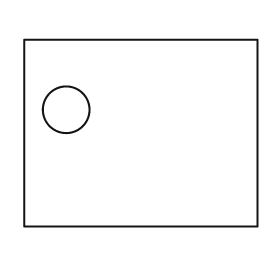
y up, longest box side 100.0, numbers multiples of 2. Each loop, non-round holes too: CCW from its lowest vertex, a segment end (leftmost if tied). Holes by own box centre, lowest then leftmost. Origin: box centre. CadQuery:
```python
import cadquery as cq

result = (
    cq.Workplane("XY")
    .moveTo(-50.0, -40.0)
    .lineTo(50.0, -40.0)
    .lineTo(50.0, 40.0)
    .lineTo(-50.0, 40.0)
    .close()
    .moveTo(-32.0, 10.0)
    .circle(10.0)
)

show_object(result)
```